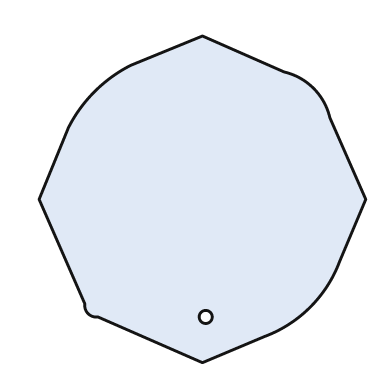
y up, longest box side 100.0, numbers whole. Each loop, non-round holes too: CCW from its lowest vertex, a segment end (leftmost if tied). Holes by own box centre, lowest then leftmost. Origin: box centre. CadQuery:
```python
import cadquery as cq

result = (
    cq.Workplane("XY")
    .moveTo(0.0, -50.0)
    .lineTo(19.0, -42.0)
    .threePointArc((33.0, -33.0), (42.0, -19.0))
    .lineTo(50.0, 0.0)
    .lineTo(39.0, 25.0)
    .threePointArc((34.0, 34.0), (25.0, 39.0))
    .lineTo(0.0, 50.0)
    .lineTo(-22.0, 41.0)
    .threePointArc((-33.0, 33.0), (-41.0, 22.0))
    .lineTo(-50.0, 0.0)
    .lineTo(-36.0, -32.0)
    .threePointArc((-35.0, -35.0), (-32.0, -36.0))
    .close()
    .moveTo(1.0, -36.0)
    .circle(2.0)
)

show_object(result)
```